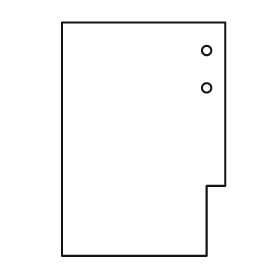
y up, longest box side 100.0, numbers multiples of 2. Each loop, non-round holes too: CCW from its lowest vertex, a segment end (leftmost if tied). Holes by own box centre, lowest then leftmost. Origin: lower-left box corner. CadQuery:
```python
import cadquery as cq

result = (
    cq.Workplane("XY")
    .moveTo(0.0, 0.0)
    .lineTo(62.0, 0.0)
    .lineTo(62.0, 30.0)
    .lineTo(70.0, 30.0)
    .lineTo(70.0, 100.0)
    .lineTo(0.0, 100.0)
    .close()
    .moveTo(62.0, 72.0)
    .circle(2.0)
    .moveTo(62.0, 88.0)
    .circle(2.0)
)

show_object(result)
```